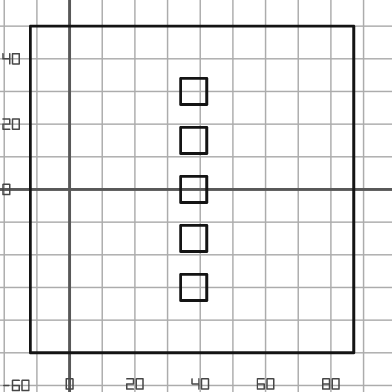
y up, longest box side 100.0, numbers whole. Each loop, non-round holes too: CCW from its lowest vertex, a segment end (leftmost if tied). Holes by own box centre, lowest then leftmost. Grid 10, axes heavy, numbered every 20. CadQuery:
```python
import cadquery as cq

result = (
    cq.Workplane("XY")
    .moveTo(-12.0, -50.0)
    .lineTo(87.0, -50.0)
    .lineTo(87.0, 50.0)
    .lineTo(-12.0, 50.0)
    .close()
    .moveTo(34.0, -34.0)
    .lineTo(42.0, -34.0)
    .lineTo(42.0, -26.0)
    .lineTo(34.0, -26.0)
    .close()
    .moveTo(34.0, -19.0)
    .lineTo(42.0, -19.0)
    .lineTo(42.0, -11.0)
    .lineTo(34.0, -11.0)
    .close()
    .moveTo(34.0, -4.0)
    .lineTo(42.0, -4.0)
    .lineTo(42.0, 4.0)
    .lineTo(34.0, 4.0)
    .close()
    .moveTo(34.0, 11.0)
    .lineTo(42.0, 11.0)
    .lineTo(42.0, 19.0)
    .lineTo(34.0, 19.0)
    .close()
    .moveTo(34.0, 26.0)
    .lineTo(42.0, 26.0)
    .lineTo(42.0, 34.0)
    .lineTo(34.0, 34.0)
    .close()
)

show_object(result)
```